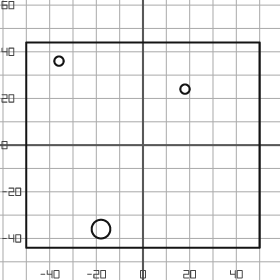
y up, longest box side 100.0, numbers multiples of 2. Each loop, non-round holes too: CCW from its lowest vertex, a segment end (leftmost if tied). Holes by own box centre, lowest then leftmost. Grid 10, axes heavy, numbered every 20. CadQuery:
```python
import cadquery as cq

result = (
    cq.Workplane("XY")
    .moveTo(-50.0, -44.0)
    .lineTo(50.0, -44.0)
    .lineTo(50.0, 44.0)
    .lineTo(-50.0, 44.0)
    .close()
    .moveTo(-18.0, -36.0)
    .circle(4.0)
    .moveTo(18.0, 24.0)
    .circle(2.0)
    .moveTo(-36.0, 36.0)
    .circle(2.0)
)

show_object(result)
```